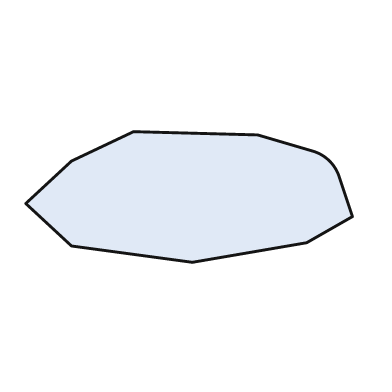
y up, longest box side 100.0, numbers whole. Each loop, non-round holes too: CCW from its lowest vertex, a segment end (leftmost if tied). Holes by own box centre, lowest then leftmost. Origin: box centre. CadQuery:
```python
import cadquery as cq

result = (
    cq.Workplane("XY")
    .moveTo(1.0, -20.0)
    .lineTo(36.0, -14.0)
    .lineTo(50.0, -6.0)
    .lineTo(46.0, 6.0)
    .threePointArc((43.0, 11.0), (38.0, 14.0))
    .lineTo(21.0, 19.0)
    .lineTo(-17.0, 20.0)
    .lineTo(-36.0, 11.0)
    .lineTo(-50.0, -2.0)
    .lineTo(-36.0, -15.0)
    .close()
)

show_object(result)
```